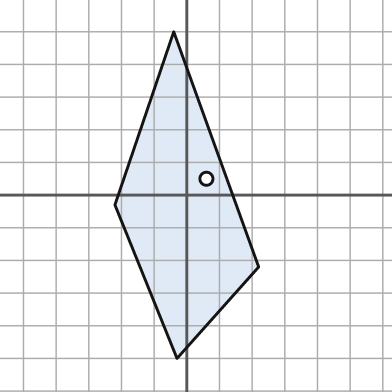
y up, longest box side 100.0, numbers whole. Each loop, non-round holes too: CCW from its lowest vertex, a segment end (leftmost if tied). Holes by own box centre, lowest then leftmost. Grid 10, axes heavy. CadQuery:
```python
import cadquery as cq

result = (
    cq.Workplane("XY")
    .moveTo(-3.0, -50.0)
    .lineTo(22.0, -22.0)
    .lineTo(-4.0, 50.0)
    .lineTo(-22.0, -3.0)
    .close()
    .moveTo(6.0, 5.0)
    .circle(2.0)
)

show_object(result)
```